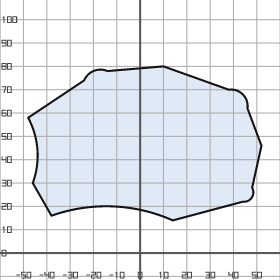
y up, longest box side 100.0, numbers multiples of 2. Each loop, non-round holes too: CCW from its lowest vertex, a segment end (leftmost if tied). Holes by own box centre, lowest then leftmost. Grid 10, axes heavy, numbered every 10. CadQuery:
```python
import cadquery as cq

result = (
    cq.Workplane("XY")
    .moveTo(14.0, 14.0)
    .lineTo(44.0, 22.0)
    .threePointArc((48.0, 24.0), (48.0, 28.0))
    .lineTo(52.0, 46.0)
    .lineTo(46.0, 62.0)
    .threePointArc((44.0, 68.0), (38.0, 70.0))
    .lineTo(10.0, 80.0)
    .lineTo(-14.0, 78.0)
    .threePointArc((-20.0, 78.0), (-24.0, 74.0))
    .lineTo(-48.0, 58.0)
    .threePointArc((-44.0, 44.0), (-46.0, 30.0))
    .lineTo(-38.0, 16.0)
    .threePointArc((-12.0, 20.0), (14.0, 14.0))
    .close()
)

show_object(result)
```